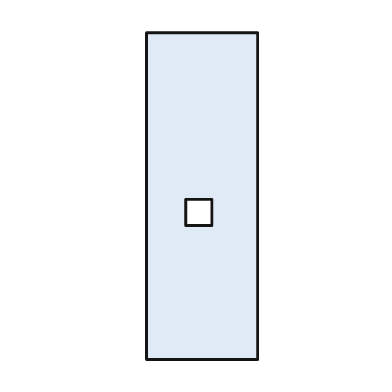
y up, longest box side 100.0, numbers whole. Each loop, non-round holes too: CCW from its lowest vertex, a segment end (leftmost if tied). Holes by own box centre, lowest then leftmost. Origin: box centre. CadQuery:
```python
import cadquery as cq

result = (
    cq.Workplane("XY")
    .moveTo(-17.0, -50.0)
    .lineTo(17.0, -50.0)
    .lineTo(17.0, 50.0)
    .lineTo(-17.0, 50.0)
    .close()
    .moveTo(-5.0, -9.0)
    .lineTo(3.0, -9.0)
    .lineTo(3.0, -1.0)
    .lineTo(-5.0, -1.0)
    .close()
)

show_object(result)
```